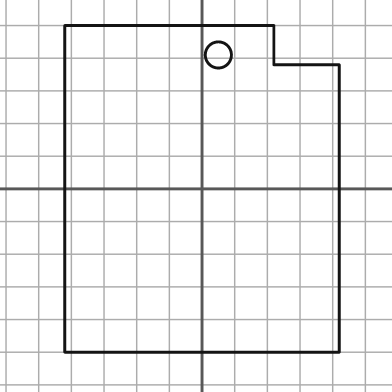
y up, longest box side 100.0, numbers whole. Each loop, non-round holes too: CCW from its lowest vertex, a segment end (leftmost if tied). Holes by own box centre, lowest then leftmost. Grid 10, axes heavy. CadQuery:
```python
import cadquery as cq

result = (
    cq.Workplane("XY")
    .moveTo(-42.0, -50.0)
    .lineTo(42.0, -50.0)
    .lineTo(42.0, 38.0)
    .lineTo(22.0, 38.0)
    .lineTo(22.0, 50.0)
    .lineTo(-42.0, 50.0)
    .close()
    .moveTo(5.0, 41.0)
    .circle(4.0)
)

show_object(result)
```